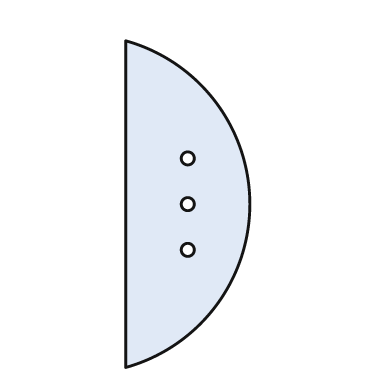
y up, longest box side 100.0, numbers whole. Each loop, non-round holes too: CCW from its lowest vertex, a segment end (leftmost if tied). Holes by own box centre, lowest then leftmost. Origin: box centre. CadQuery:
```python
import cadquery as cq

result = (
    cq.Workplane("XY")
    .moveTo(-19.0, -50.0)
    .threePointArc((19.0, 0.0), (-19.0, 50.0))
    .close()
    .moveTo(0.0, -14.0)
    .circle(2.0)
    .moveTo(0.0, 0.0)
    .circle(2.0)
    .moveTo(0.0, 14.0)
    .circle(2.0)
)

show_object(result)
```